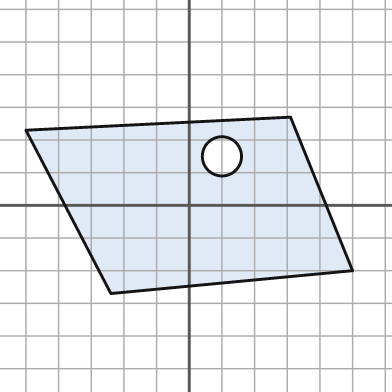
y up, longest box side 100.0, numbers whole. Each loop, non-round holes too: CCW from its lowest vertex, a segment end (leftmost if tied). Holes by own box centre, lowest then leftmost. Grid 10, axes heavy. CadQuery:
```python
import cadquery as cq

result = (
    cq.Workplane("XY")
    .moveTo(-24.0, -27.0)
    .lineTo(50.0, -20.0)
    .lineTo(31.0, 27.0)
    .lineTo(-50.0, 23.0)
    .close()
    .moveTo(10.0, 15.0)
    .circle(6.0)
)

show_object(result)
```